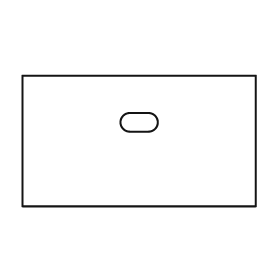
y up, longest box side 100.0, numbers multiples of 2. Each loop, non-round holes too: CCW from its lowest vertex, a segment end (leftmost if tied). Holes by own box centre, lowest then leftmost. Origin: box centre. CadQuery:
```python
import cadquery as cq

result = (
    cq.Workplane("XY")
    .moveTo(-50.0, -28.0)
    .lineTo(50.0, -28.0)
    .lineTo(50.0, 28.0)
    .lineTo(-50.0, 28.0)
    .close()
    .moveTo(-4.0, 4.0)
    .lineTo(4.0, 4.0)
    .threePointArc((8.0, 8.0), (4.0, 12.0))
    .lineTo(-4.0, 12.0)
    .threePointArc((-8.0, 8.0), (-4.0, 4.0))
    .close()
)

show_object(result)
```